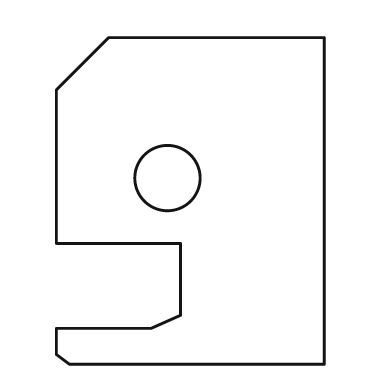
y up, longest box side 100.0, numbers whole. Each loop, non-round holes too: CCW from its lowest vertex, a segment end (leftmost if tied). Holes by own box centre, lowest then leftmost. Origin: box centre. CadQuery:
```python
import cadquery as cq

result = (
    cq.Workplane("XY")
    .moveTo(-37.0, -50.0)
    .lineTo(41.0, -50.0)
    .lineTo(41.0, 50.0)
    .lineTo(-25.0, 50.0)
    .lineTo(-41.0, 34.0)
    .lineTo(-41.0, -13.0)
    .lineTo(-3.0, -13.0)
    .lineTo(-3.0, -35.0)
    .lineTo(-12.0, -39.0)
    .lineTo(-41.0, -39.0)
    .lineTo(-41.0, -47.0)
    .close()
    .moveTo(-7.0, 7.0)
    .circle(10.0)
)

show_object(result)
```